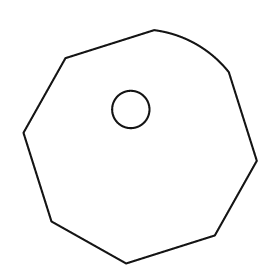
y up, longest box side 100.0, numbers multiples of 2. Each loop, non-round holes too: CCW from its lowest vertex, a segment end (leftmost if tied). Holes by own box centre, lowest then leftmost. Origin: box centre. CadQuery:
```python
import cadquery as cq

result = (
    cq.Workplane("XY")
    .moveTo(-6.0, -50.0)
    .lineTo(32.0, -38.0)
    .lineTo(50.0, -6.0)
    .lineTo(38.0, 32.0)
    .threePointArc((24.0, 44.0), (6.0, 50.0))
    .lineTo(-32.0, 38.0)
    .lineTo(-50.0, 6.0)
    .lineTo(-38.0, -32.0)
    .close()
    .moveTo(-4.0, 16.0)
    .circle(8.0)
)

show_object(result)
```